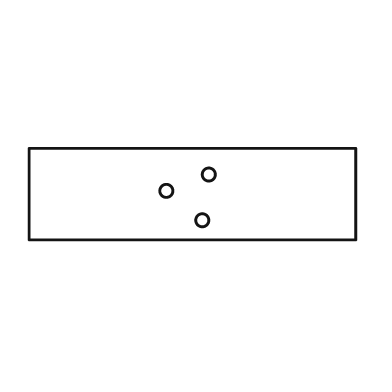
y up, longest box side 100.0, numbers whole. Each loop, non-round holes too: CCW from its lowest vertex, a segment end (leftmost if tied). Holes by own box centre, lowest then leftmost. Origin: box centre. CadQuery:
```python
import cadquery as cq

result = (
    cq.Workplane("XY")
    .moveTo(-50.0, -14.0)
    .lineTo(50.0, -14.0)
    .lineTo(50.0, 14.0)
    .lineTo(-50.0, 14.0)
    .close()
    .moveTo(3.0, -8.0)
    .circle(2.0)
    .moveTo(-8.0, 1.0)
    .circle(2.0)
    .moveTo(5.0, 6.0)
    .circle(2.0)
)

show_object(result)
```